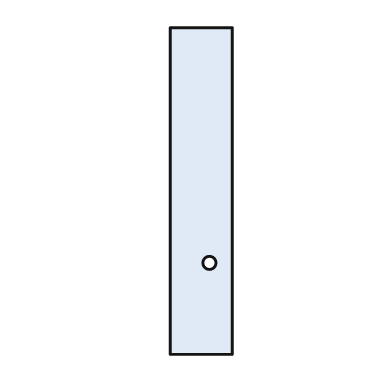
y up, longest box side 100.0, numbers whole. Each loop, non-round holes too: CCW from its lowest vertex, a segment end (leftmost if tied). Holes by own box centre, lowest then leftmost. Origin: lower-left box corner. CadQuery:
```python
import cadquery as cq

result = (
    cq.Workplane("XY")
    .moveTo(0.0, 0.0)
    .lineTo(19.0, 0.0)
    .lineTo(19.0, 100.0)
    .lineTo(0.0, 100.0)
    .close()
    .moveTo(12.0, 28.0)
    .circle(2.0)
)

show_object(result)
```